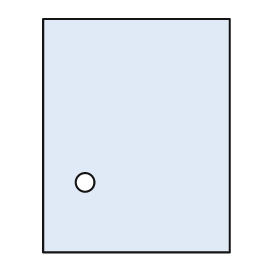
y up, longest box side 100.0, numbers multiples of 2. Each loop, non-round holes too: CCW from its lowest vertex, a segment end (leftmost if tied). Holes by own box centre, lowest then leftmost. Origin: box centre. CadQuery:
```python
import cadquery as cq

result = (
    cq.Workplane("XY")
    .moveTo(-40.0, -50.0)
    .lineTo(40.0, -50.0)
    .lineTo(40.0, 50.0)
    .lineTo(-40.0, 50.0)
    .close()
    .moveTo(-22.0, -20.0)
    .circle(4.0)
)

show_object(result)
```